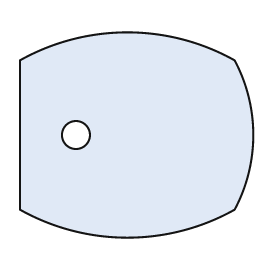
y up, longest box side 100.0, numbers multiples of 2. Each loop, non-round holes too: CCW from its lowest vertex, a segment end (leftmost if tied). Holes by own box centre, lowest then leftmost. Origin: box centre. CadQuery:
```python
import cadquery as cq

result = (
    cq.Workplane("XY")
    .moveTo(-50.0, -32.0)
    .threePointArc((-4.0, -44.0), (42.0, -32.0))
    .threePointArc((50.0, 0.0), (42.0, 32.0))
    .threePointArc((-4.0, 44.0), (-50.0, 32.0))
    .close()
    .moveTo(-26.0, 0.0)
    .circle(6.0)
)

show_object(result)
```